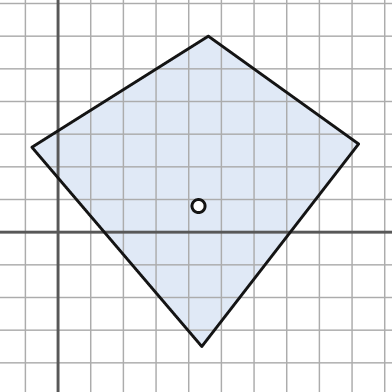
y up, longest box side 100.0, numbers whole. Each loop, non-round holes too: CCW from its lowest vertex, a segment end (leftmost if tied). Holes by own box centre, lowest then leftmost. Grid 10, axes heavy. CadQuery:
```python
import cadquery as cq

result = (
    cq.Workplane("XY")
    .moveTo(44.0, -35.0)
    .lineTo(92.0, 27.0)
    .lineTo(46.0, 60.0)
    .lineTo(-8.0, 26.0)
    .close()
    .moveTo(43.0, 8.0)
    .circle(2.0)
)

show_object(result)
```